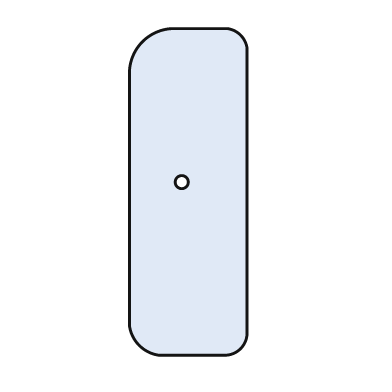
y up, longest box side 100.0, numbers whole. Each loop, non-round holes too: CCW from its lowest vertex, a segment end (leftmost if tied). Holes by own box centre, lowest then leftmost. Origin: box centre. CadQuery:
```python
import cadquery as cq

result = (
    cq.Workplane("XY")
    .moveTo(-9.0, -50.0)
    .lineTo(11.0, -50.0)
    .threePointArc((16.0, -48.0), (18.0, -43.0))
    .lineTo(18.0, 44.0)
    .threePointArc((16.0, 48.0), (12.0, 50.0))
    .lineTo(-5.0, 50.0)
    .threePointArc((-14.0, 46.0), (-18.0, 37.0))
    .lineTo(-18.0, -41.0)
    .threePointArc((-15.0, -47.0), (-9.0, -50.0))
    .close()
    .moveTo(-2.0, 3.0)
    .circle(2.0)
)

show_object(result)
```